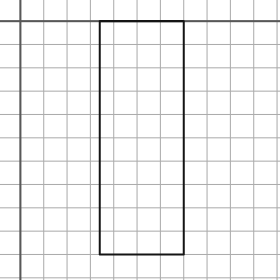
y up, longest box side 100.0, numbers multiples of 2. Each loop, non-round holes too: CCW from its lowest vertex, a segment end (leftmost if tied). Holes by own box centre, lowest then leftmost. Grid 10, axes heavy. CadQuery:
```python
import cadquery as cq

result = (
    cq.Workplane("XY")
    .moveTo(34.0, -100.0)
    .lineTo(70.0, -100.0)
    .lineTo(70.0, 0.0)
    .lineTo(34.0, 0.0)
    .close()
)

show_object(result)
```